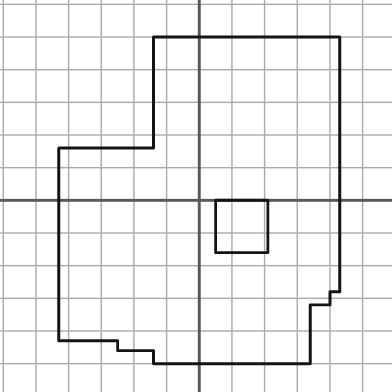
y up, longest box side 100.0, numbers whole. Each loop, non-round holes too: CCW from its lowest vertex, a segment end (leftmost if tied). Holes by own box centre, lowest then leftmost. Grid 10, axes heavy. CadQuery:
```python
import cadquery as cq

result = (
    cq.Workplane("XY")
    .moveTo(-14.0, -50.0)
    .lineTo(34.0, -50.0)
    .lineTo(34.0, -32.0)
    .lineTo(40.0, -32.0)
    .lineTo(40.0, -28.0)
    .lineTo(43.0, -28.0)
    .lineTo(43.0, 50.0)
    .lineTo(-14.0, 50.0)
    .lineTo(-14.0, 16.0)
    .lineTo(-43.0, 16.0)
    .lineTo(-43.0, -43.0)
    .lineTo(-25.0, -43.0)
    .lineTo(-25.0, -46.0)
    .lineTo(-14.0, -46.0)
    .close()
    .moveTo(5.0, -16.0)
    .lineTo(21.0, -16.0)
    .lineTo(21.0, 0.0)
    .lineTo(5.0, 0.0)
    .close()
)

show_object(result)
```